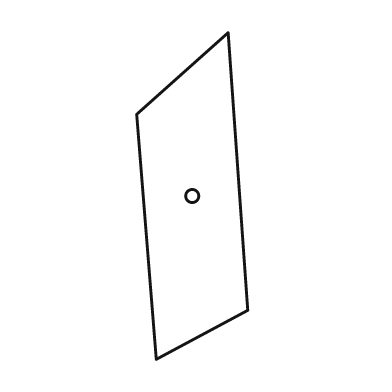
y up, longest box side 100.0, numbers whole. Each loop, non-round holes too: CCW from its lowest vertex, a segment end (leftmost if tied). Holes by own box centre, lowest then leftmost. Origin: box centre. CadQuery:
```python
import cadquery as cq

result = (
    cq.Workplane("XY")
    .moveTo(-11.0, -50.0)
    .lineTo(17.0, -35.0)
    .lineTo(11.0, 50.0)
    .lineTo(-17.0, 25.0)
    .close()
    .moveTo(0.0, 0.0)
    .circle(2.0)
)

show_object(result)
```